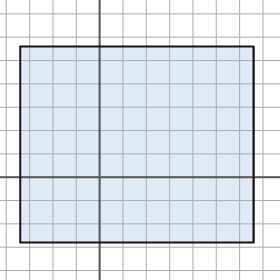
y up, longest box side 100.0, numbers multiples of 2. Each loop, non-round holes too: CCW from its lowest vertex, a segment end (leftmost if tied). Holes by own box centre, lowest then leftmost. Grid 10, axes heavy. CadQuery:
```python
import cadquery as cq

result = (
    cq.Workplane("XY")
    .moveTo(-34.0, -28.0)
    .lineTo(66.0, -28.0)
    .lineTo(66.0, 56.0)
    .lineTo(-34.0, 56.0)
    .close()
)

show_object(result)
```